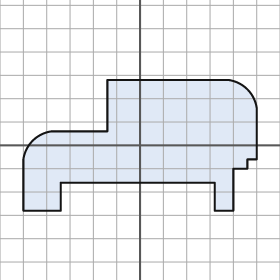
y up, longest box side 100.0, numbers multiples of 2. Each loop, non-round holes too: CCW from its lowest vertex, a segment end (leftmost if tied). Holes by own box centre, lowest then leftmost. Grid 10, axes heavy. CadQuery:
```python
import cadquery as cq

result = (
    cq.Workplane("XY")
    .moveTo(-50.0, -28.0)
    .lineTo(-34.0, -28.0)
    .lineTo(-34.0, -16.0)
    .lineTo(32.0, -16.0)
    .lineTo(32.0, -28.0)
    .lineTo(40.0, -28.0)
    .lineTo(40.0, -10.0)
    .lineTo(46.0, -10.0)
    .lineTo(46.0, -6.0)
    .lineTo(50.0, -6.0)
    .lineTo(50.0, 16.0)
    .threePointArc((46.0, 24.0), (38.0, 28.0))
    .lineTo(-14.0, 28.0)
    .lineTo(-14.0, 6.0)
    .lineTo(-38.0, 6.0)
    .threePointArc((-46.0, 2.0), (-50.0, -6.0))
    .close()
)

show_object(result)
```